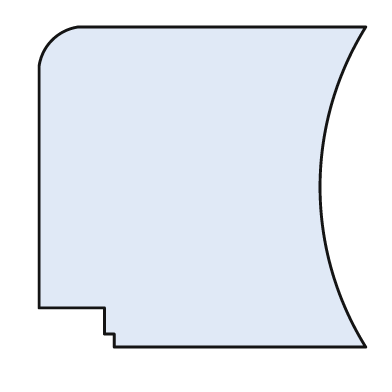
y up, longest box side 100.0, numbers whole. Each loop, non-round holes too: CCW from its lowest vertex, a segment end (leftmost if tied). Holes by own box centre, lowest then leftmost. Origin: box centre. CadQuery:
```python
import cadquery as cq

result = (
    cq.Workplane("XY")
    .moveTo(-27.0, -49.0)
    .lineTo(50.0, -49.0)
    .threePointArc((36.0, 0.0), (50.0, 49.0))
    .lineTo(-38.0, 49.0)
    .threePointArc((-46.0, 45.0), (-50.0, 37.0))
    .lineTo(-50.0, -37.0)
    .lineTo(-30.0, -37.0)
    .lineTo(-30.0, -45.0)
    .lineTo(-27.0, -45.0)
    .close()
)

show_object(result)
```